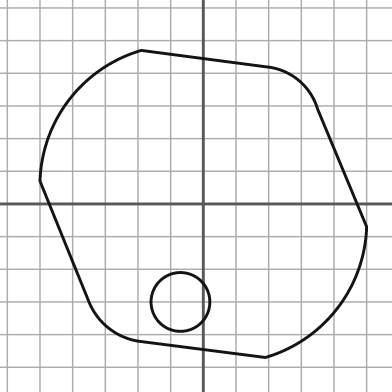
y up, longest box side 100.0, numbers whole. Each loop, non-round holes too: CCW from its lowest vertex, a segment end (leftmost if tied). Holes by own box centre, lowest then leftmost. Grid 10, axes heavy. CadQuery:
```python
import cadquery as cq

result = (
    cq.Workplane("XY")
    .moveTo(19.0, -47.0)
    .threePointArc((41.0, -32.0), (50.0, -7.0))
    .lineTo(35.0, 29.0)
    .threePointArc((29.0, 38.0), (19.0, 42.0))
    .lineTo(-19.0, 47.0)
    .threePointArc((-41.0, 32.0), (-50.0, 7.0))
    .lineTo(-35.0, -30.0)
    .threePointArc((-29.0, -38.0), (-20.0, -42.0))
    .close()
    .moveTo(-7.0, -30.0)
    .circle(9.0)
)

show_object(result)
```